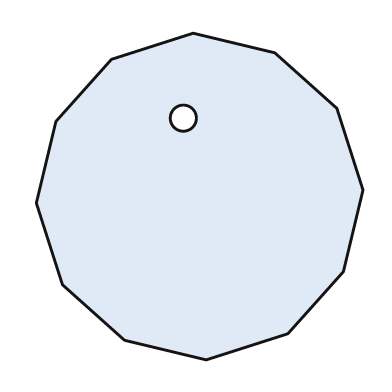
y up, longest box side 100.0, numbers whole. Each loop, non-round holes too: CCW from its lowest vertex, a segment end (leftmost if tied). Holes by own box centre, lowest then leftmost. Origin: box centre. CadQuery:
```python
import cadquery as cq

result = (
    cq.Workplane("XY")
    .moveTo(2.0, -50.0)
    .lineTo(27.0, -42.0)
    .lineTo(44.0, -23.0)
    .lineTo(50.0, 2.0)
    .lineTo(42.0, 27.0)
    .lineTo(23.0, 44.0)
    .lineTo(-2.0, 50.0)
    .lineTo(-27.0, 42.0)
    .lineTo(-44.0, 23.0)
    .lineTo(-50.0, -2.0)
    .lineTo(-42.0, -27.0)
    .lineTo(-23.0, -44.0)
    .close()
    .moveTo(-5.0, 24.0)
    .circle(4.0)
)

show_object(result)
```